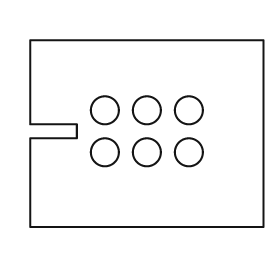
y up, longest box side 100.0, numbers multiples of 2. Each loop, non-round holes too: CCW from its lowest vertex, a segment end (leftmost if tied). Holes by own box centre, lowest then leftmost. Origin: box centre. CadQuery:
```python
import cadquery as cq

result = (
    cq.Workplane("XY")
    .moveTo(-50.0, -40.0)
    .lineTo(50.0, -40.0)
    .lineTo(50.0, 40.0)
    .lineTo(-50.0, 40.0)
    .lineTo(-50.0, 4.0)
    .lineTo(-30.0, 4.0)
    .lineTo(-30.0, -2.0)
    .lineTo(-50.0, -2.0)
    .close()
    .moveTo(-18.0, -8.0)
    .circle(6.0)
    .moveTo(0.0, -8.0)
    .circle(6.0)
    .moveTo(18.0, -8.0)
    .circle(6.0)
    .moveTo(-18.0, 10.0)
    .circle(6.0)
    .moveTo(0.0, 10.0)
    .circle(6.0)
    .moveTo(18.0, 10.0)
    .circle(6.0)
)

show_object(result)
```